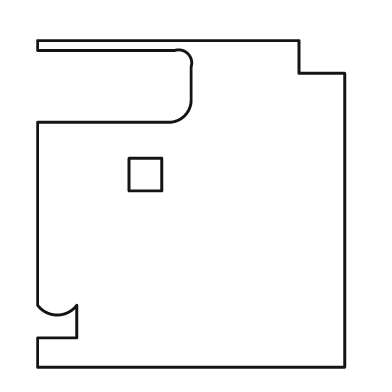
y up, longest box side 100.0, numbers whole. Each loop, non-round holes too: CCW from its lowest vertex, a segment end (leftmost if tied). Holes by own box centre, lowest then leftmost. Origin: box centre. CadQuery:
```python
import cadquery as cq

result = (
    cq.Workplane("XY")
    .moveTo(-47.0, -50.0)
    .lineTo(47.0, -50.0)
    .lineTo(47.0, 40.0)
    .lineTo(33.0, 40.0)
    .lineTo(33.0, 50.0)
    .lineTo(-47.0, 50.0)
    .lineTo(-47.0, 47.0)
    .lineTo(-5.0, 47.0)
    .threePointArc((-1.0, 46.0), (0.0, 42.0))
    .lineTo(0.0, 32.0)
    .threePointArc((-2.0, 27.0), (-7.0, 25.0))
    .lineTo(-47.0, 25.0)
    .lineTo(-47.0, -31.0)
    .threePointArc((-41.0, -34.0), (-35.0, -31.0))
    .lineTo(-35.0, -41.0)
    .lineTo(-47.0, -41.0)
    .close()
    .moveTo(-19.0, 4.0)
    .lineTo(-9.0, 4.0)
    .lineTo(-9.0, 14.0)
    .lineTo(-19.0, 14.0)
    .close()
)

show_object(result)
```